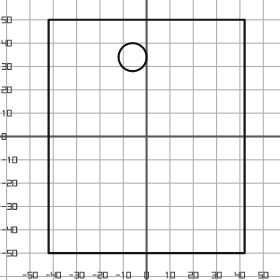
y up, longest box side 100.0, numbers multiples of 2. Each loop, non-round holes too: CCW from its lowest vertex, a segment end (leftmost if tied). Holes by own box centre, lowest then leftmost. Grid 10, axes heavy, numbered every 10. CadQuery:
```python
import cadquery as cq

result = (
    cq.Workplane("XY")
    .moveTo(-42.0, -50.0)
    .lineTo(42.0, -50.0)
    .lineTo(42.0, 50.0)
    .lineTo(-42.0, 50.0)
    .close()
    .moveTo(-6.0, 34.0)
    .circle(6.0)
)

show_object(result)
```